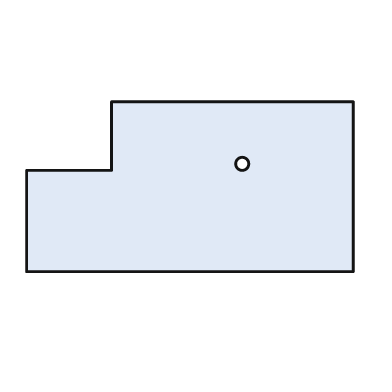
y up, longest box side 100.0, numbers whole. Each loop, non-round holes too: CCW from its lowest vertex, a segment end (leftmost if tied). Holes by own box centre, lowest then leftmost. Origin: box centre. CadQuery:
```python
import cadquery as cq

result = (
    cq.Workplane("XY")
    .moveTo(-50.0, -26.0)
    .lineTo(50.0, -26.0)
    .lineTo(50.0, 26.0)
    .lineTo(-24.0, 26.0)
    .lineTo(-24.0, 5.0)
    .lineTo(-50.0, 5.0)
    .close()
    .moveTo(16.0, 7.0)
    .circle(2.0)
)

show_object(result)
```